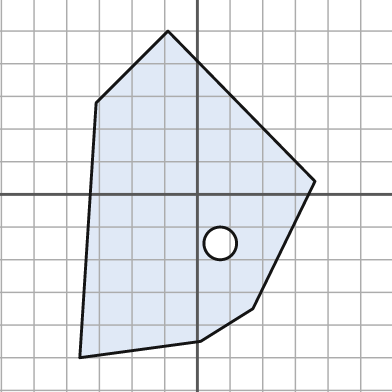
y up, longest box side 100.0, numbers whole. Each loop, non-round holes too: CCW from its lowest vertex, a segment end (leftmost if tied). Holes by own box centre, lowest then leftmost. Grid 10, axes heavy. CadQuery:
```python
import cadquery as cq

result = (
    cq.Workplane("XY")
    .moveTo(-36.0, -50.0)
    .lineTo(1.0, -45.0)
    .lineTo(17.0, -35.0)
    .lineTo(36.0, 4.0)
    .lineTo(-9.0, 50.0)
    .lineTo(-31.0, 28.0)
    .close()
    .moveTo(7.0, -15.0)
    .circle(5.0)
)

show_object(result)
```